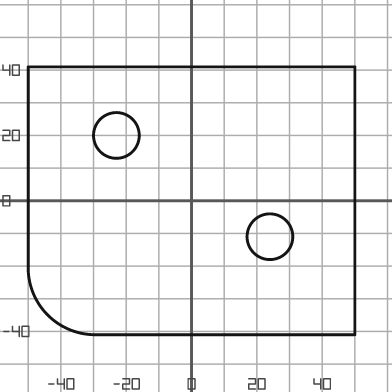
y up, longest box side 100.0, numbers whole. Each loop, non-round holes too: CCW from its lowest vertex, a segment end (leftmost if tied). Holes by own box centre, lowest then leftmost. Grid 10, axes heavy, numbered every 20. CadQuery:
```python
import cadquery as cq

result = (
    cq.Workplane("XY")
    .moveTo(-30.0, -41.0)
    .lineTo(50.0, -41.0)
    .lineTo(50.0, 41.0)
    .lineTo(-50.0, 41.0)
    .lineTo(-50.0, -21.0)
    .threePointArc((-44.0, -35.0), (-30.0, -41.0))
    .close()
    .moveTo(24.0, -11.0)
    .circle(7.0)
    .moveTo(-23.0, 20.0)
    .circle(7.0)
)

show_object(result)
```